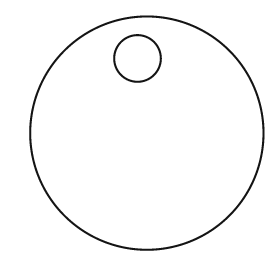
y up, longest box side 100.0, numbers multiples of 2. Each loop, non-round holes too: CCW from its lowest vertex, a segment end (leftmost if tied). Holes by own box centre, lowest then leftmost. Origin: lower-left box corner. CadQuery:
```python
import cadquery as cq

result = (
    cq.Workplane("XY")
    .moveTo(50.0, 50.0)
    .circle(50.0)
    .moveTo(46.0, 82.0)
    .circle(10.0)
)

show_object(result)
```